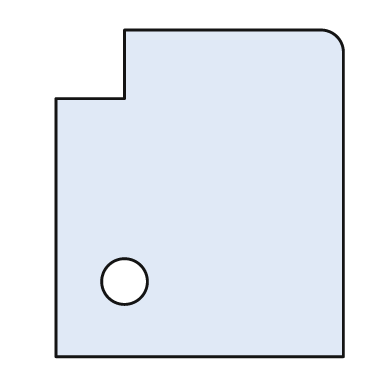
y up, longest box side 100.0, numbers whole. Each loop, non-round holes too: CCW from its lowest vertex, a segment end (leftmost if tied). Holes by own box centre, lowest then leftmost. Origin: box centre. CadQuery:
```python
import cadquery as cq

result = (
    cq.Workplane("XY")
    .moveTo(-44.0, -50.0)
    .lineTo(44.0, -50.0)
    .lineTo(44.0, 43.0)
    .threePointArc((42.0, 48.0), (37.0, 50.0))
    .lineTo(-23.0, 50.0)
    .lineTo(-23.0, 29.0)
    .lineTo(-44.0, 29.0)
    .close()
    .moveTo(-23.0, -27.0)
    .circle(7.0)
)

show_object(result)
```